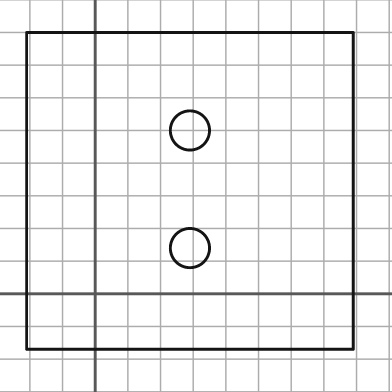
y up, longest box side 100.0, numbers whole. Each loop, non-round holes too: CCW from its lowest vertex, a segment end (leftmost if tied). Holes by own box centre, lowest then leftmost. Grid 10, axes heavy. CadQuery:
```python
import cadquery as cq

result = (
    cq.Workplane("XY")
    .moveTo(-21.0, -17.0)
    .lineTo(79.0, -17.0)
    .lineTo(79.0, 80.0)
    .lineTo(-21.0, 80.0)
    .close()
    .moveTo(29.0, 14.0)
    .circle(6.0)
    .moveTo(29.0, 50.0)
    .circle(6.0)
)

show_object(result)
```